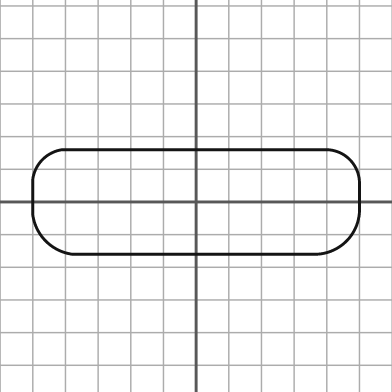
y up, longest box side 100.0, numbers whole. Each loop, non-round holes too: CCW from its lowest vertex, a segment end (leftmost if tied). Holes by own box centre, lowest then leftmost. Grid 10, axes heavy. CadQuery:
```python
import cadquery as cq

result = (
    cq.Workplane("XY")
    .moveTo(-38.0, -16.0)
    .lineTo(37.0, -16.0)
    .threePointArc((46.0, -12.0), (50.0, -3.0))
    .lineTo(50.0, 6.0)
    .threePointArc((47.0, 13.0), (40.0, 16.0))
    .lineTo(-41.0, 16.0)
    .threePointArc((-47.0, 13.0), (-50.0, 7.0))
    .lineTo(-50.0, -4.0)
    .threePointArc((-46.0, -12.0), (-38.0, -16.0))
    .close()
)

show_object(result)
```